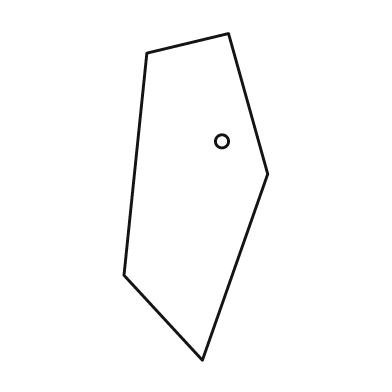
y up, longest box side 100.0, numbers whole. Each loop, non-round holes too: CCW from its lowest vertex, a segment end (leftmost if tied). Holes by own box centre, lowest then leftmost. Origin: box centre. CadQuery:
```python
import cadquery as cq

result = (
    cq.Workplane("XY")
    .moveTo(2.0, -50.0)
    .lineTo(22.0, 7.0)
    .lineTo(10.0, 50.0)
    .lineTo(-15.0, 44.0)
    .lineTo(-22.0, -24.0)
    .close()
    .moveTo(8.0, 17.0)
    .circle(2.0)
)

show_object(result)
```